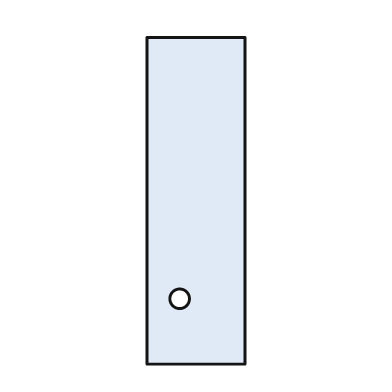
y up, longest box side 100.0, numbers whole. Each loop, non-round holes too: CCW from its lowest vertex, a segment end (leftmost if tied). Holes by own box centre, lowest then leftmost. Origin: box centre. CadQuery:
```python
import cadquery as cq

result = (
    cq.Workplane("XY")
    .moveTo(-15.0, -50.0)
    .lineTo(15.0, -50.0)
    .lineTo(15.0, 50.0)
    .lineTo(-15.0, 50.0)
    .close()
    .moveTo(-5.0, -30.0)
    .circle(3.0)
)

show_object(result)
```